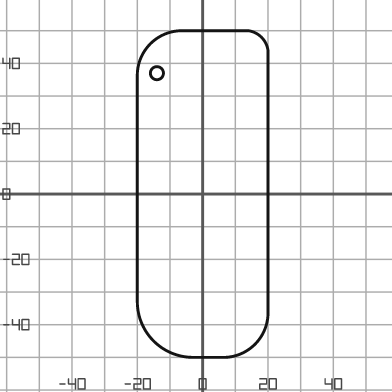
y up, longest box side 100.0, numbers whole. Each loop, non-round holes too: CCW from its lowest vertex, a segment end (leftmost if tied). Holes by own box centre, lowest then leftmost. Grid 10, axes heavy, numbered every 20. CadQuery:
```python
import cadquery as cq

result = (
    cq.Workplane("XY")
    .moveTo(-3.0, -50.0)
    .lineTo(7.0, -50.0)
    .threePointArc((16.0, -46.0), (20.0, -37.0))
    .lineTo(20.0, 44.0)
    .threePointArc((18.0, 48.0), (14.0, 50.0))
    .lineTo(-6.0, 50.0)
    .threePointArc((-16.0, 46.0), (-20.0, 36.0))
    .lineTo(-20.0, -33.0)
    .threePointArc((-15.0, -45.0), (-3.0, -50.0))
    .close()
    .moveTo(-14.0, 37.0)
    .circle(2.0)
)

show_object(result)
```